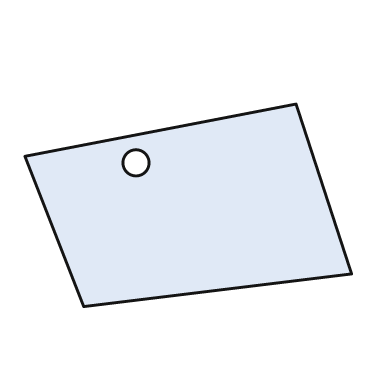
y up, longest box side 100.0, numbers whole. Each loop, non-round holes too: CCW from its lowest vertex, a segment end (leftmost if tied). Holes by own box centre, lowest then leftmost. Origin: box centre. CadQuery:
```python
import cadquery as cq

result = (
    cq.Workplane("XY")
    .moveTo(-32.0, -31.0)
    .lineTo(50.0, -21.0)
    .lineTo(33.0, 31.0)
    .lineTo(-50.0, 15.0)
    .close()
    .moveTo(-16.0, 13.0)
    .circle(4.0)
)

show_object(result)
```